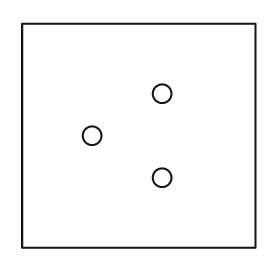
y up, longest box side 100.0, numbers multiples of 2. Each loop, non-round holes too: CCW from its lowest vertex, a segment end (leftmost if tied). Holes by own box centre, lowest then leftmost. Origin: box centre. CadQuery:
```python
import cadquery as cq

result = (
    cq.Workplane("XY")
    .moveTo(-50.0, -48.0)
    .lineTo(50.0, -48.0)
    .lineTo(50.0, 48.0)
    .lineTo(-50.0, 48.0)
    .close()
    .moveTo(10.0, -18.0)
    .circle(4.0)
    .moveTo(-20.0, 0.0)
    .circle(4.0)
    .moveTo(10.0, 18.0)
    .circle(4.0)
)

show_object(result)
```